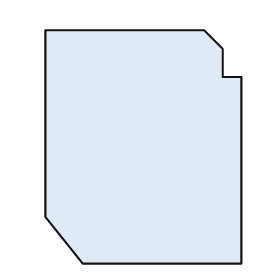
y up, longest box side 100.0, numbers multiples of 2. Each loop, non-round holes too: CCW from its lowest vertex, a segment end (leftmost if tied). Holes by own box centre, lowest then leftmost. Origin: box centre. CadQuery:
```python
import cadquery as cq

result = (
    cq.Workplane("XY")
    .moveTo(-26.0, -50.0)
    .lineTo(42.0, -50.0)
    .lineTo(42.0, 30.0)
    .lineTo(34.0, 30.0)
    .lineTo(34.0, 42.0)
    .lineTo(26.0, 50.0)
    .lineTo(-42.0, 50.0)
    .lineTo(-42.0, -30.0)
    .close()
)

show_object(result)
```